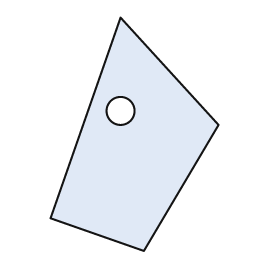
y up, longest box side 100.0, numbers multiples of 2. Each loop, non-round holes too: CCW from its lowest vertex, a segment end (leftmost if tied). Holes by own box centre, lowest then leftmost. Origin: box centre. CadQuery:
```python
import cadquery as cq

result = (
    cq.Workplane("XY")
    .moveTo(4.0, -50.0)
    .lineTo(36.0, 4.0)
    .lineTo(-6.0, 50.0)
    .lineTo(-36.0, -36.0)
    .close()
    .moveTo(-6.0, 10.0)
    .circle(6.0)
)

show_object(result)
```